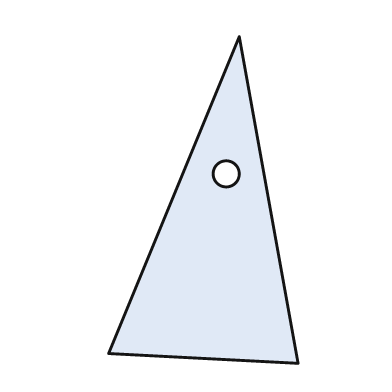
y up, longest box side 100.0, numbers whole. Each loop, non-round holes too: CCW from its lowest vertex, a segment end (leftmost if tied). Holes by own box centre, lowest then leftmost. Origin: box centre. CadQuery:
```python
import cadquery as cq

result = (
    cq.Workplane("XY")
    .moveTo(29.0, -50.0)
    .lineTo(11.0, 50.0)
    .lineTo(-29.0, -47.0)
    .close()
    .moveTo(7.0, 8.0)
    .circle(4.0)
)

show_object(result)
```